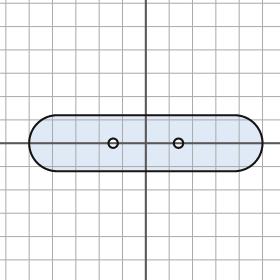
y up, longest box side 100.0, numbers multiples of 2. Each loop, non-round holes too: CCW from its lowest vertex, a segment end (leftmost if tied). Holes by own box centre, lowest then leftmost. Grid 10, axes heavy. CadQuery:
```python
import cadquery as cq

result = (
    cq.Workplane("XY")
    .moveTo(-38.0, -12.0)
    .lineTo(38.0, -12.0)
    .threePointArc((50.0, 0.0), (38.0, 12.0))
    .lineTo(-38.0, 12.0)
    .threePointArc((-50.0, 0.0), (-38.0, -12.0))
    .close()
    .moveTo(-14.0, 0.0)
    .circle(2.0)
    .moveTo(14.0, 0.0)
    .circle(2.0)
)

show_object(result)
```